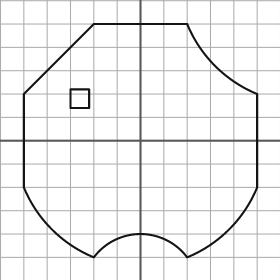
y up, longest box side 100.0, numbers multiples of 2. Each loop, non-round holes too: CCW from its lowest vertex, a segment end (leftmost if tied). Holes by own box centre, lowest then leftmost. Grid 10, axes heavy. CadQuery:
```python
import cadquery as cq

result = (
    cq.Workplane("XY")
    .moveTo(-20.0, -50.0)
    .threePointArc((0.0, -40.0), (20.0, -50.0))
    .threePointArc((38.0, -38.0), (50.0, -20.0))
    .lineTo(50.0, 20.0)
    .threePointArc((32.0, 32.0), (20.0, 50.0))
    .lineTo(-20.0, 50.0)
    .lineTo(-50.0, 20.0)
    .lineTo(-50.0, -20.0)
    .threePointArc((-38.0, -38.0), (-20.0, -50.0))
    .close()
    .moveTo(-30.0, 14.0)
    .lineTo(-22.0, 14.0)
    .lineTo(-22.0, 22.0)
    .lineTo(-30.0, 22.0)
    .close()
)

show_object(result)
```